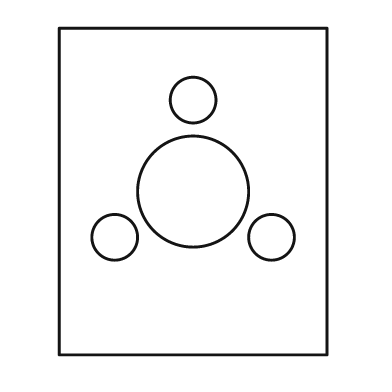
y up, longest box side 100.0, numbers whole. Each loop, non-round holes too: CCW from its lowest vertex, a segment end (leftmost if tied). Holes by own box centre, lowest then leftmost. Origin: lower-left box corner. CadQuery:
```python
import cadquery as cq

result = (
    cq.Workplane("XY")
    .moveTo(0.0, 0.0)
    .lineTo(82.0, 0.0)
    .lineTo(82.0, 100.0)
    .lineTo(0.0, 100.0)
    .close()
    .moveTo(17.0, 36.0)
    .circle(7.0)
    .moveTo(65.0, 36.0)
    .circle(7.0)
    .moveTo(41.0, 50.0)
    .circle(17.0)
    .moveTo(41.0, 78.0)
    .circle(7.0)
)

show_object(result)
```